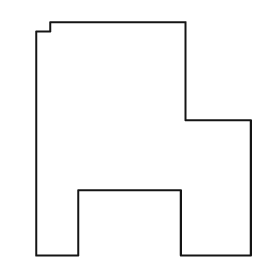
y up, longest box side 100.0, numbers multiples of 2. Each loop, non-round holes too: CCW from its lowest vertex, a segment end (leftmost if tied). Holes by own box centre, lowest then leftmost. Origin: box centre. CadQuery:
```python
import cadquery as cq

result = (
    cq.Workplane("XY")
    .moveTo(-46.0, -50.0)
    .lineTo(-28.0, -50.0)
    .lineTo(-28.0, -22.0)
    .lineTo(16.0, -22.0)
    .lineTo(16.0, -50.0)
    .lineTo(46.0, -50.0)
    .lineTo(46.0, 8.0)
    .lineTo(18.0, 8.0)
    .lineTo(18.0, 50.0)
    .lineTo(-40.0, 50.0)
    .lineTo(-40.0, 46.0)
    .lineTo(-46.0, 46.0)
    .close()
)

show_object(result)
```